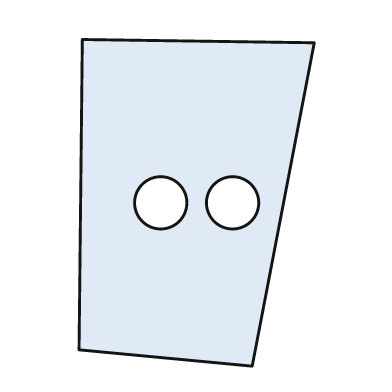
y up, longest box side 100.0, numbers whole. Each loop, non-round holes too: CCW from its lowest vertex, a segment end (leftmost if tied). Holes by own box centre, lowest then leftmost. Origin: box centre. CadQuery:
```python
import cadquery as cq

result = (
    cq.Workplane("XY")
    .moveTo(17.0, -50.0)
    .lineTo(36.0, 49.0)
    .lineTo(-35.0, 50.0)
    .lineTo(-36.0, -45.0)
    .close()
    .moveTo(-11.0, 0.0)
    .circle(8.0)
    .moveTo(11.0, 0.0)
    .circle(8.0)
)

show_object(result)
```